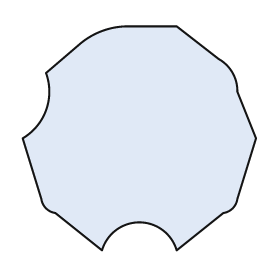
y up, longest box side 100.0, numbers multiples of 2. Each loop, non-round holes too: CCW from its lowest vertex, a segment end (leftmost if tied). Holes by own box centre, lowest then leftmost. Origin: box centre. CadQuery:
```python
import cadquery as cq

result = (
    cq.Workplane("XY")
    .moveTo(-16.0, -48.0)
    .threePointArc((0.0, -36.0), (16.0, -48.0))
    .lineTo(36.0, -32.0)
    .threePointArc((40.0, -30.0), (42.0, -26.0))
    .lineTo(50.0, 0.0)
    .lineTo(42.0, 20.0)
    .threePointArc((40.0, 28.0), (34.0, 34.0))
    .lineTo(16.0, 48.0)
    .lineTo(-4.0, 48.0)
    .threePointArc((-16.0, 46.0), (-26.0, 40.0))
    .lineTo(-40.0, 28.0)
    .threePointArc((-40.0, 12.0), (-50.0, 0.0))
    .lineTo(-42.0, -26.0)
    .threePointArc((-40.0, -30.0), (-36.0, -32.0))
    .close()
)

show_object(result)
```